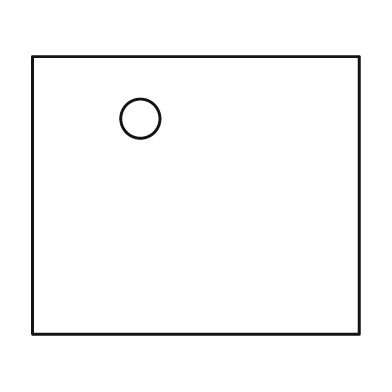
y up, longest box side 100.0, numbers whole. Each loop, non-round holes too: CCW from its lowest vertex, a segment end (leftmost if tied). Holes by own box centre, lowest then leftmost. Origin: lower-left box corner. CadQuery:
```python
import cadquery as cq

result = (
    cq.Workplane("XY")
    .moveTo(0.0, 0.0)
    .lineTo(100.0, 0.0)
    .lineTo(100.0, 85.0)
    .lineTo(0.0, 85.0)
    .close()
    .moveTo(33.0, 66.0)
    .circle(6.0)
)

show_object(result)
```